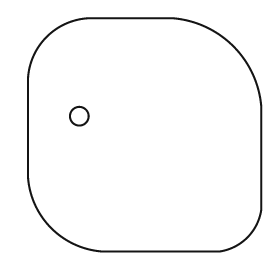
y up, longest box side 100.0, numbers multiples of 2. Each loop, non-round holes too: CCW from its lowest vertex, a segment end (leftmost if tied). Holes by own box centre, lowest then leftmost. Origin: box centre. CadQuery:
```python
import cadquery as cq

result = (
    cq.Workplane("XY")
    .moveTo(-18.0, -50.0)
    .lineTo(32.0, -50.0)
    .threePointArc((44.0, -44.0), (50.0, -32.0))
    .lineTo(50.0, 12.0)
    .threePointArc((38.0, 38.0), (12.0, 50.0))
    .lineTo(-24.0, 50.0)
    .threePointArc((-42.0, 42.0), (-50.0, 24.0))
    .lineTo(-50.0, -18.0)
    .threePointArc((-40.0, -40.0), (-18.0, -50.0))
    .close()
    .moveTo(-28.0, 8.0)
    .circle(4.0)
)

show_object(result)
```